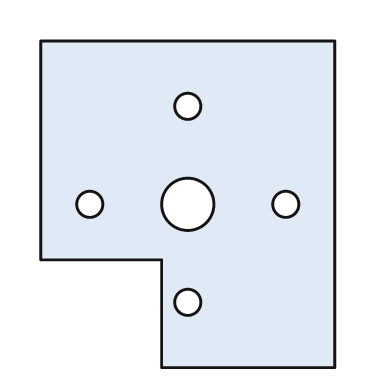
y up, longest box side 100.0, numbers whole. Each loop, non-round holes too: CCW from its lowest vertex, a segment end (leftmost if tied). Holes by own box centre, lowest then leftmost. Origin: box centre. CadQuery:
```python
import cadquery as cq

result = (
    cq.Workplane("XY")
    .moveTo(-8.0, -50.0)
    .lineTo(45.0, -50.0)
    .lineTo(45.0, 50.0)
    .lineTo(-45.0, 50.0)
    .lineTo(-45.0, -17.0)
    .lineTo(-8.0, -17.0)
    .close()
    .moveTo(0.0, -30.0)
    .circle(4.0)
    .moveTo(-30.0, 0.0)
    .circle(4.0)
    .moveTo(0.0, 0.0)
    .circle(8.0)
    .moveTo(30.0, 0.0)
    .circle(4.0)
    .moveTo(0.0, 30.0)
    .circle(4.0)
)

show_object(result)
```